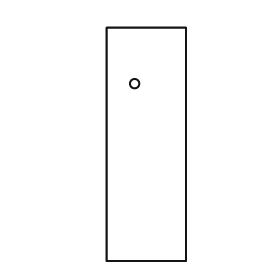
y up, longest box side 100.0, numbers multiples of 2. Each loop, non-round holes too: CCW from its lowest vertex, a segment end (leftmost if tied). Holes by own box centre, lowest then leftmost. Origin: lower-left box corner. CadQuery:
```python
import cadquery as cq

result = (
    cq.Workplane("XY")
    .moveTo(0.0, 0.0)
    .lineTo(34.0, 0.0)
    .lineTo(34.0, 100.0)
    .lineTo(0.0, 100.0)
    .close()
    .moveTo(12.0, 76.0)
    .circle(2.0)
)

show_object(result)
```